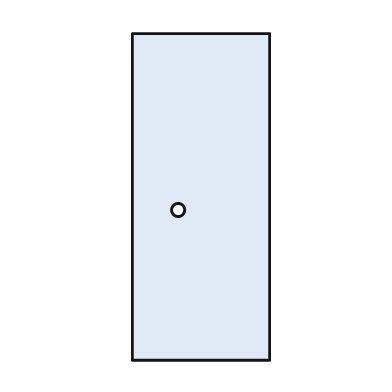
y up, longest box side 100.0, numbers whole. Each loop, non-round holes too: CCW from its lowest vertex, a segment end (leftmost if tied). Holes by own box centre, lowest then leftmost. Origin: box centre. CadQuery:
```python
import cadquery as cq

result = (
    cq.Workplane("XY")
    .moveTo(-21.0, -50.0)
    .lineTo(21.0, -50.0)
    .lineTo(21.0, 50.0)
    .lineTo(-21.0, 50.0)
    .close()
    .moveTo(-7.0, -4.0)
    .circle(2.0)
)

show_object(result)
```